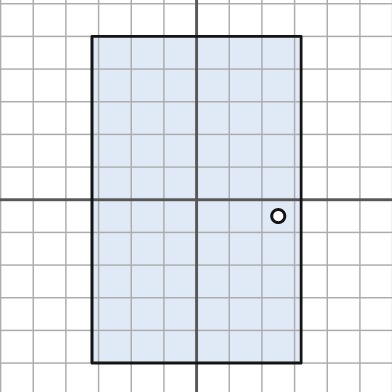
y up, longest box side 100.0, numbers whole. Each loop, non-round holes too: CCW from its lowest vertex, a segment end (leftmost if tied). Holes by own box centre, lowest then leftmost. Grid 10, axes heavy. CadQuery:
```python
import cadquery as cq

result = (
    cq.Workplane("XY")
    .moveTo(-32.0, -50.0)
    .lineTo(32.0, -50.0)
    .lineTo(32.0, 50.0)
    .lineTo(-32.0, 50.0)
    .close()
    .moveTo(25.0, -5.0)
    .circle(2.0)
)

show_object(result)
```